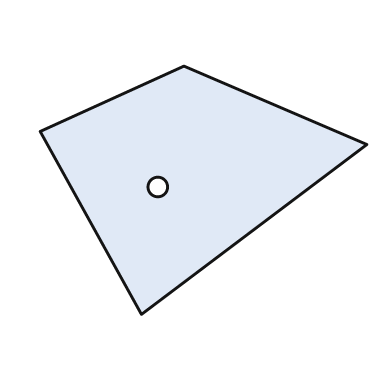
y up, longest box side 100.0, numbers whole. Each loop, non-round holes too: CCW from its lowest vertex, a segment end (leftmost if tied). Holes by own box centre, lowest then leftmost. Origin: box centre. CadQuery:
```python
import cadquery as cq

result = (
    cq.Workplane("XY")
    .moveTo(-19.0, -38.0)
    .lineTo(50.0, 14.0)
    .lineTo(-6.0, 38.0)
    .lineTo(-50.0, 18.0)
    .close()
    .moveTo(-14.0, 1.0)
    .circle(3.0)
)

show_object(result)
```